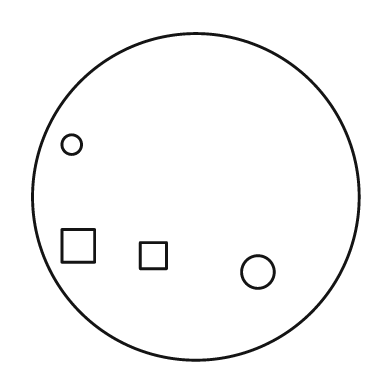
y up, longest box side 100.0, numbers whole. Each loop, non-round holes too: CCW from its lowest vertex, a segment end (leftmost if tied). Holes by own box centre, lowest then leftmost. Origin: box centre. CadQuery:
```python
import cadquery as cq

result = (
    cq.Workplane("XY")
    .moveTo(0.0, 0.0)
    .circle(50.0)
    .moveTo(19.0, -23.0)
    .circle(5.0)
    .moveTo(-17.0, -22.0)
    .lineTo(-9.0, -22.0)
    .lineTo(-9.0, -14.0)
    .lineTo(-17.0, -14.0)
    .close()
    .moveTo(-41.0, -20.0)
    .lineTo(-31.0, -20.0)
    .lineTo(-31.0, -10.0)
    .lineTo(-41.0, -10.0)
    .close()
    .moveTo(-38.0, 16.0)
    .circle(3.0)
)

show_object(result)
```